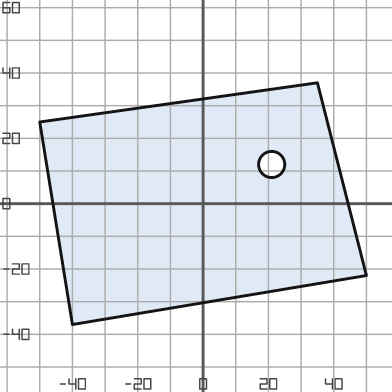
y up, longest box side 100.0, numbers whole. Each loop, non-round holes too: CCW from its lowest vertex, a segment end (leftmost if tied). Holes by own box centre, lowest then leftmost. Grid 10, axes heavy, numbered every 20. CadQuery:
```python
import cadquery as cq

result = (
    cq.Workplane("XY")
    .moveTo(-40.0, -37.0)
    .lineTo(50.0, -22.0)
    .lineTo(35.0, 37.0)
    .lineTo(-50.0, 25.0)
    .close()
    .moveTo(21.0, 12.0)
    .circle(4.0)
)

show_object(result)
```